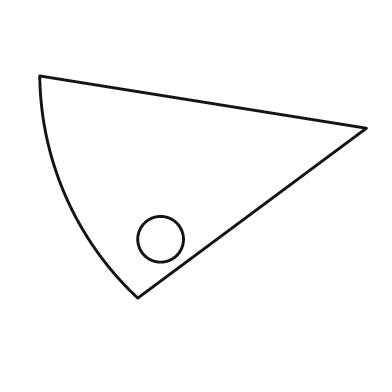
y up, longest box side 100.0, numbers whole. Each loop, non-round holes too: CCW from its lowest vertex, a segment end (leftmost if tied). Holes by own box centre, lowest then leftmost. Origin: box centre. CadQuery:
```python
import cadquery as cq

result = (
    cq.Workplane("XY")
    .moveTo(-20.0, -34.0)
    .lineTo(50.0, 18.0)
    .lineTo(-50.0, 34.0)
    .threePointArc((-42.0, -3.0), (-20.0, -34.0))
    .close()
    .moveTo(-13.0, -16.0)
    .circle(7.0)
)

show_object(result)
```